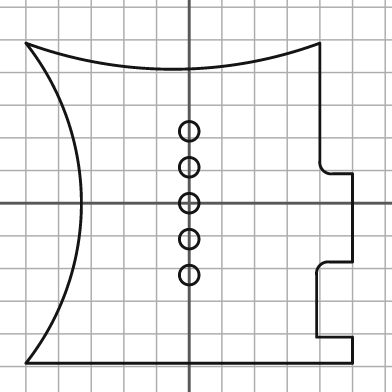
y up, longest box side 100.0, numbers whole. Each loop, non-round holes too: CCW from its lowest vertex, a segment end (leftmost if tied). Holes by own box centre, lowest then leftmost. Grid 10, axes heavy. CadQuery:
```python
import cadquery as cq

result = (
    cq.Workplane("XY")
    .moveTo(-50.0, -49.0)
    .lineTo(50.0, -49.0)
    .lineTo(50.0, -41.0)
    .lineTo(39.0, -41.0)
    .lineTo(39.0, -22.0)
    .threePointArc((40.0, -19.0), (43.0, -18.0))
    .lineTo(50.0, -18.0)
    .lineTo(50.0, 9.0)
    .lineTo(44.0, 9.0)
    .threePointArc((41.0, 10.0), (40.0, 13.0))
    .lineTo(40.0, 49.0)
    .threePointArc((-5.0, 41.0), (-50.0, 49.0))
    .threePointArc((-33.0, 0.0), (-50.0, -49.0))
    .close()
    .moveTo(0.0, -22.0)
    .circle(3.0)
    .moveTo(0.0, -11.0)
    .circle(3.0)
    .moveTo(0.0, 0.0)
    .circle(3.0)
    .moveTo(0.0, 11.0)
    .circle(3.0)
    .moveTo(0.0, 22.0)
    .circle(3.0)
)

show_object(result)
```